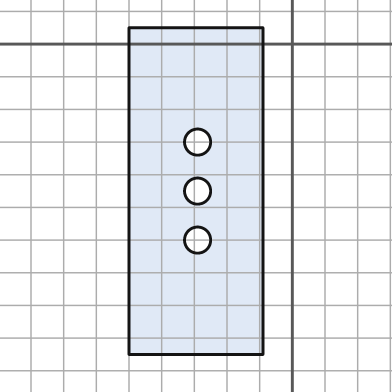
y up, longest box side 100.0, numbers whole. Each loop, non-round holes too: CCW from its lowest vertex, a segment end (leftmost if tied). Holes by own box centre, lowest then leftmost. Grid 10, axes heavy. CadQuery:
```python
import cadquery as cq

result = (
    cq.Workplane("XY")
    .moveTo(-50.0, -95.0)
    .lineTo(-9.0, -95.0)
    .lineTo(-9.0, 5.0)
    .lineTo(-50.0, 5.0)
    .close()
    .moveTo(-29.0, -60.0)
    .circle(4.0)
    .moveTo(-29.0, -45.0)
    .circle(4.0)
    .moveTo(-29.0, -30.0)
    .circle(4.0)
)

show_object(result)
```